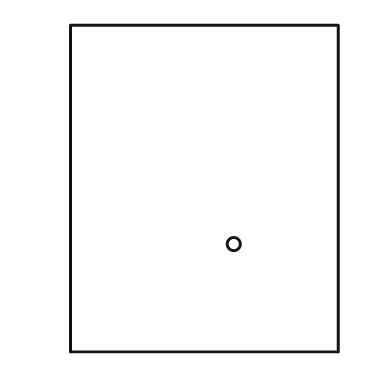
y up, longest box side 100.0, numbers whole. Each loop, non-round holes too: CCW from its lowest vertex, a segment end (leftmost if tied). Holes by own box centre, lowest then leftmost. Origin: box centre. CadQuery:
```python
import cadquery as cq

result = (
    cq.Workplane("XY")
    .moveTo(-41.0, -50.0)
    .lineTo(41.0, -50.0)
    .lineTo(41.0, 50.0)
    .lineTo(-41.0, 50.0)
    .close()
    .moveTo(9.0, -17.0)
    .circle(2.0)
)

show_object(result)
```